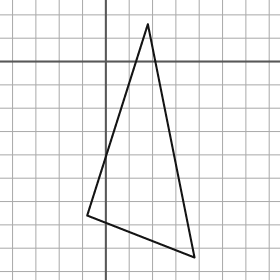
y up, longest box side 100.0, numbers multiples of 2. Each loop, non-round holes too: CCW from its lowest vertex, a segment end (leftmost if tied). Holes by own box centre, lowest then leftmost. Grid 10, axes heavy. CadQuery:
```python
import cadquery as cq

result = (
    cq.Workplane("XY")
    .moveTo(38.0, -84.0)
    .lineTo(18.0, 16.0)
    .lineTo(-8.0, -66.0)
    .close()
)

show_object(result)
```